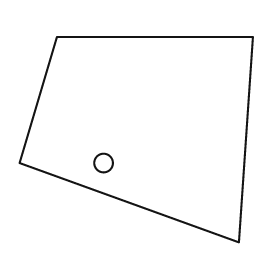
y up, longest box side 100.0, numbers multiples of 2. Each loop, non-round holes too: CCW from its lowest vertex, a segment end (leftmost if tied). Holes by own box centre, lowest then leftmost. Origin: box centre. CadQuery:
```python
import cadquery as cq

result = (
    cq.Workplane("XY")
    .moveTo(44.0, -44.0)
    .lineTo(50.0, 44.0)
    .lineTo(-34.0, 44.0)
    .lineTo(-50.0, -10.0)
    .close()
    .moveTo(-14.0, -10.0)
    .circle(4.0)
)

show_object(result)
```